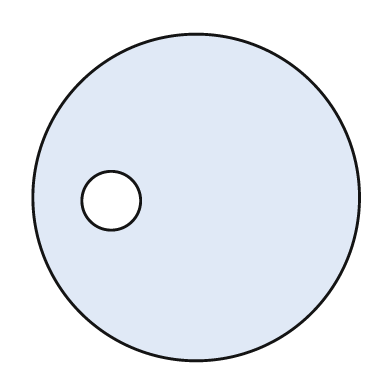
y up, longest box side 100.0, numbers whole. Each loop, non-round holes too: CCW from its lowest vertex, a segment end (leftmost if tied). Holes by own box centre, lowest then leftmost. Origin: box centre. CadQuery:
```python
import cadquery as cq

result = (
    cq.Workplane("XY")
    .moveTo(0.0, 0.0)
    .circle(50.0)
    .moveTo(-26.0, -1.0)
    .circle(9.0)
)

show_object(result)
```